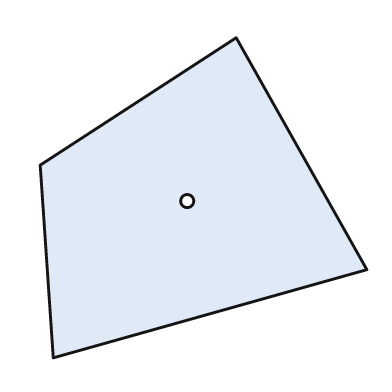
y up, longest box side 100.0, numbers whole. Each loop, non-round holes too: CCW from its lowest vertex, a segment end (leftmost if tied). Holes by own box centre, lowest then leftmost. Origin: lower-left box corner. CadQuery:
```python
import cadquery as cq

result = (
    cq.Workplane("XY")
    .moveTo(4.0, 0.0)
    .lineTo(100.0, 27.0)
    .lineTo(60.0, 98.0)
    .lineTo(0.0, 59.0)
    .close()
    .moveTo(45.0, 48.0)
    .circle(2.0)
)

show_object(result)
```